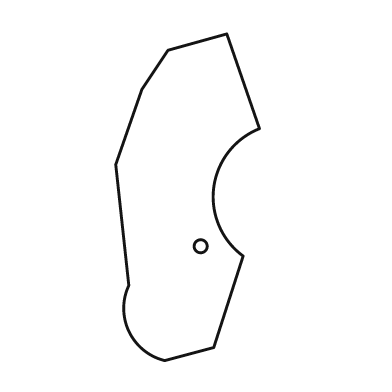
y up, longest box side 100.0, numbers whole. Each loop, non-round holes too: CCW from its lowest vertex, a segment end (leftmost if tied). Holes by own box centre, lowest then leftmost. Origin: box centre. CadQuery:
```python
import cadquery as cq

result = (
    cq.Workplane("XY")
    .moveTo(-7.0, -50.0)
    .lineTo(8.0, -46.0)
    .lineTo(17.0, -18.0)
    .threePointArc((8.0, 3.0), (22.0, 21.0))
    .lineTo(12.0, 50.0)
    .lineTo(-6.0, 45.0)
    .lineTo(-14.0, 33.0)
    .lineTo(-22.0, 10.0)
    .lineTo(-18.0, -27.0)
    .threePointArc((-18.0, -41.0), (-7.0, -50.0))
    .close()
    .moveTo(4.0, -15.0)
    .circle(2.0)
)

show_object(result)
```